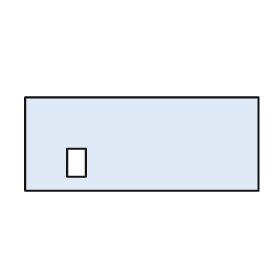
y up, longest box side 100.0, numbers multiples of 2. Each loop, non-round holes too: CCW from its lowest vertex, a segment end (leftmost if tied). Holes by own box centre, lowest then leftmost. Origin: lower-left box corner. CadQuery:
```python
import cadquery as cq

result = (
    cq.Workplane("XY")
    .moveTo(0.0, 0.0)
    .lineTo(100.0, 0.0)
    .lineTo(100.0, 40.0)
    .lineTo(0.0, 40.0)
    .close()
    .moveTo(18.0, 6.0)
    .lineTo(26.0, 6.0)
    .lineTo(26.0, 18.0)
    .lineTo(18.0, 18.0)
    .close()
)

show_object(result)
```